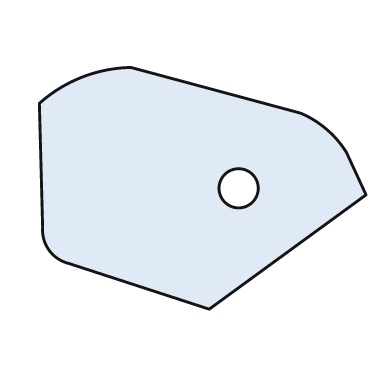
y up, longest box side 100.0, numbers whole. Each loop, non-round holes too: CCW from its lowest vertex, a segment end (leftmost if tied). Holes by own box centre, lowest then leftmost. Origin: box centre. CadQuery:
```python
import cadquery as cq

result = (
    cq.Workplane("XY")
    .moveTo(2.0, -37.0)
    .lineTo(50.0, -2.0)
    .lineTo(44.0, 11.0)
    .threePointArc((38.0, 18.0), (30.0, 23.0))
    .lineTo(-22.0, 37.0)
    .threePointArc((-37.0, 34.0), (-50.0, 26.0))
    .lineTo(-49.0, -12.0)
    .threePointArc((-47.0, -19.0), (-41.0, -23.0))
    .close()
    .moveTo(11.0, 0.0)
    .circle(6.0)
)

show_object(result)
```